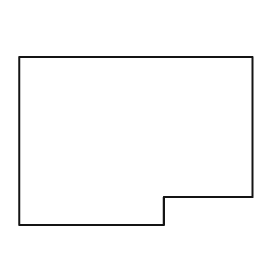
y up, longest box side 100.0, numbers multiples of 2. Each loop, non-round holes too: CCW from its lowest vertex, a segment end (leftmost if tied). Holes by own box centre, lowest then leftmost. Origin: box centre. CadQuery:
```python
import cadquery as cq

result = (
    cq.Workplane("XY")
    .moveTo(-50.0, -36.0)
    .lineTo(12.0, -36.0)
    .lineTo(12.0, -24.0)
    .lineTo(50.0, -24.0)
    .lineTo(50.0, 36.0)
    .lineTo(-50.0, 36.0)
    .close()
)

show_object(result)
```